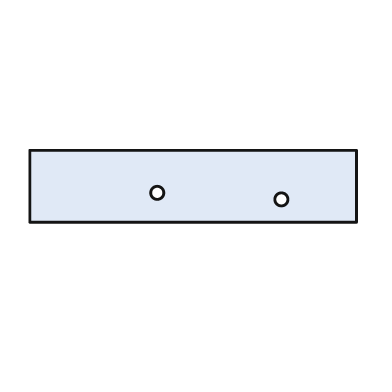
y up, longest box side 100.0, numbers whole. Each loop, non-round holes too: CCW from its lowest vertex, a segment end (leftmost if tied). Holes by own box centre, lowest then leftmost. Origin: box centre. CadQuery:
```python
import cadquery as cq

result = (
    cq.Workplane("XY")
    .moveTo(-50.0, -11.0)
    .lineTo(50.0, -11.0)
    .lineTo(50.0, 11.0)
    .lineTo(-50.0, 11.0)
    .close()
    .moveTo(27.0, -4.0)
    .circle(2.0)
    .moveTo(-11.0, -2.0)
    .circle(2.0)
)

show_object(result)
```